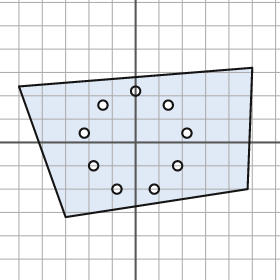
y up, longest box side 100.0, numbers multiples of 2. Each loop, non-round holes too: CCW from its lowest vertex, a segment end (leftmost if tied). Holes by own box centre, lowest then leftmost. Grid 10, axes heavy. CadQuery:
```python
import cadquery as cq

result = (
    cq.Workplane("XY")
    .moveTo(-30.0, -32.0)
    .lineTo(48.0, -20.0)
    .lineTo(50.0, 32.0)
    .lineTo(-50.0, 24.0)
    .close()
    .moveTo(-8.0, -20.0)
    .circle(2.0)
    .moveTo(8.0, -20.0)
    .circle(2.0)
    .moveTo(-18.0, -10.0)
    .circle(2.0)
    .moveTo(18.0, -10.0)
    .circle(2.0)
    .moveTo(-22.0, 4.0)
    .circle(2.0)
    .moveTo(22.0, 4.0)
    .circle(2.0)
    .moveTo(-14.0, 16.0)
    .circle(2.0)
    .moveTo(14.0, 16.0)
    .circle(2.0)
    .moveTo(0.0, 22.0)
    .circle(2.0)
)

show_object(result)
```